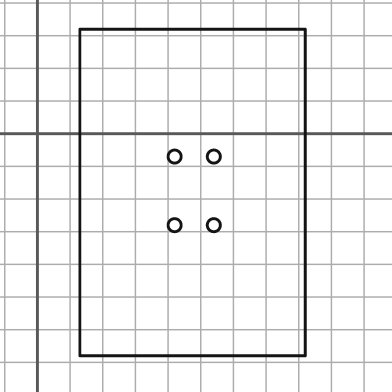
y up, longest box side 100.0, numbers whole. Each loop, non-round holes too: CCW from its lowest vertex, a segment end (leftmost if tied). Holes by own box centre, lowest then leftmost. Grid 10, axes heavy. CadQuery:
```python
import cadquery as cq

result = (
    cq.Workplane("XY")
    .moveTo(13.0, -68.0)
    .lineTo(82.0, -68.0)
    .lineTo(82.0, 32.0)
    .lineTo(13.0, 32.0)
    .close()
    .moveTo(42.0, -28.0)
    .circle(2.0)
    .moveTo(54.0, -28.0)
    .circle(2.0)
    .moveTo(42.0, -7.0)
    .circle(2.0)
    .moveTo(54.0, -7.0)
    .circle(2.0)
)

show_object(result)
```